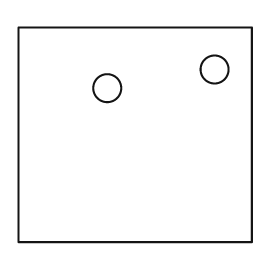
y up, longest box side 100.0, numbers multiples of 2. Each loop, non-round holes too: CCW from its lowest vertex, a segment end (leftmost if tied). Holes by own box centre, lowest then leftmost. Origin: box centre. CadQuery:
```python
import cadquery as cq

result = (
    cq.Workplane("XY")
    .moveTo(-50.0, -46.0)
    .lineTo(50.0, -46.0)
    .lineTo(50.0, 46.0)
    .lineTo(-50.0, 46.0)
    .close()
    .moveTo(-12.0, 20.0)
    .circle(6.0)
    .moveTo(34.0, 28.0)
    .circle(6.0)
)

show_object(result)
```